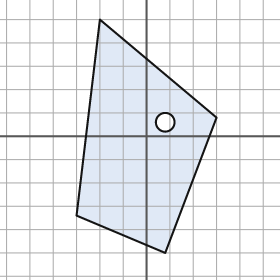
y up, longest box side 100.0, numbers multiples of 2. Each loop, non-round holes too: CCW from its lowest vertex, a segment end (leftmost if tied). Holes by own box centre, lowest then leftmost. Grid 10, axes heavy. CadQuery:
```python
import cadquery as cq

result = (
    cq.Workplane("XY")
    .moveTo(8.0, -50.0)
    .lineTo(30.0, 8.0)
    .lineTo(-20.0, 50.0)
    .lineTo(-30.0, -34.0)
    .close()
    .moveTo(8.0, 6.0)
    .circle(4.0)
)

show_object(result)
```